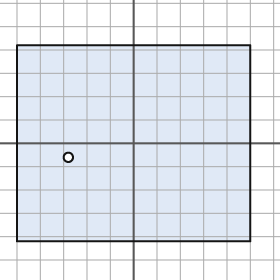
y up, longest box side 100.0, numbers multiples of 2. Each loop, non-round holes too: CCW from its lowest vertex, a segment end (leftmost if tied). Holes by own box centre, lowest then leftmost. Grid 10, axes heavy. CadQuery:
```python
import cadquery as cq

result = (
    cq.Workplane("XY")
    .moveTo(-50.0, -42.0)
    .lineTo(50.0, -42.0)
    .lineTo(50.0, 42.0)
    .lineTo(-50.0, 42.0)
    .close()
    .moveTo(-28.0, -6.0)
    .circle(2.0)
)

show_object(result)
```